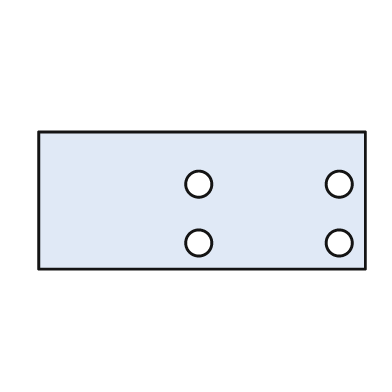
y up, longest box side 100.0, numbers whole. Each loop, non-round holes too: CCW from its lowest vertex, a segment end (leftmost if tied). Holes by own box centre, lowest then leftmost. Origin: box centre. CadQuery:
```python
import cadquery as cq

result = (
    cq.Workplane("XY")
    .moveTo(-50.0, -21.0)
    .lineTo(50.0, -21.0)
    .lineTo(50.0, 21.0)
    .lineTo(-50.0, 21.0)
    .close()
    .moveTo(-1.0, -13.0)
    .circle(4.0)
    .moveTo(42.0, -13.0)
    .circle(4.0)
    .moveTo(-1.0, 5.0)
    .circle(4.0)
    .moveTo(42.0, 5.0)
    .circle(4.0)
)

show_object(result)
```